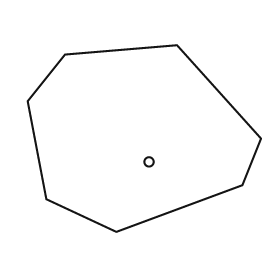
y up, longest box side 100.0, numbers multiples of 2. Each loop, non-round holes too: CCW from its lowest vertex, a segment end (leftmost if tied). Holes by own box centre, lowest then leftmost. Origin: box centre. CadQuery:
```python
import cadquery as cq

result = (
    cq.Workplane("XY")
    .moveTo(-12.0, -40.0)
    .lineTo(42.0, -20.0)
    .lineTo(50.0, 0.0)
    .lineTo(14.0, 40.0)
    .lineTo(-34.0, 36.0)
    .lineTo(-50.0, 16.0)
    .lineTo(-42.0, -26.0)
    .close()
    .moveTo(2.0, -10.0)
    .circle(2.0)
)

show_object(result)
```